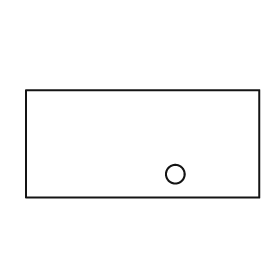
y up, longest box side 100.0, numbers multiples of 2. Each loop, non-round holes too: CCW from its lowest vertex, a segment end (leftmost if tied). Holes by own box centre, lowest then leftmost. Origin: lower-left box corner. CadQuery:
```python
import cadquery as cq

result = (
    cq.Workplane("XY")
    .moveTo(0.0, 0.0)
    .lineTo(100.0, 0.0)
    .lineTo(100.0, 46.0)
    .lineTo(0.0, 46.0)
    .close()
    .moveTo(64.0, 10.0)
    .circle(4.0)
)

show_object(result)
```